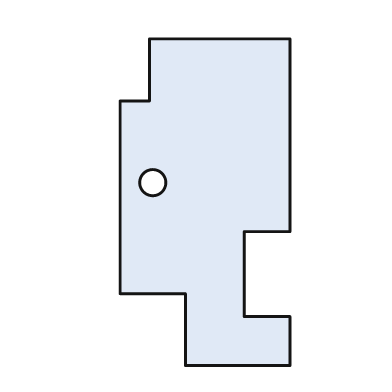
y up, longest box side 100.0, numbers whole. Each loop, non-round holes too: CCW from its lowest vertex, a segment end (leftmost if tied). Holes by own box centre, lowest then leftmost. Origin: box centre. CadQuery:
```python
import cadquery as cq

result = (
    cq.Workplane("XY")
    .moveTo(-6.0, -50.0)
    .lineTo(26.0, -50.0)
    .lineTo(26.0, -35.0)
    .lineTo(12.0, -35.0)
    .lineTo(12.0, -9.0)
    .lineTo(26.0, -9.0)
    .lineTo(26.0, 50.0)
    .lineTo(-17.0, 50.0)
    .lineTo(-17.0, 31.0)
    .lineTo(-26.0, 31.0)
    .lineTo(-26.0, -28.0)
    .lineTo(-6.0, -28.0)
    .close()
    .moveTo(-16.0, 6.0)
    .circle(4.0)
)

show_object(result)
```